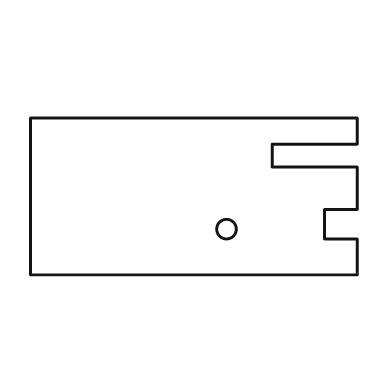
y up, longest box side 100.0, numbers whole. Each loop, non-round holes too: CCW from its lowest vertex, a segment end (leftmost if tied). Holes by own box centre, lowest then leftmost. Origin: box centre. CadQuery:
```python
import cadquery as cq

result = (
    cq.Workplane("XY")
    .moveTo(-50.0, -24.0)
    .lineTo(50.0, -24.0)
    .lineTo(50.0, -13.0)
    .lineTo(40.0, -13.0)
    .lineTo(40.0, -4.0)
    .lineTo(50.0, -4.0)
    .lineTo(50.0, 9.0)
    .lineTo(24.0, 9.0)
    .lineTo(24.0, 16.0)
    .lineTo(50.0, 16.0)
    .lineTo(50.0, 24.0)
    .lineTo(-50.0, 24.0)
    .close()
    .moveTo(10.0, -10.0)
    .circle(3.0)
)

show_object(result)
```